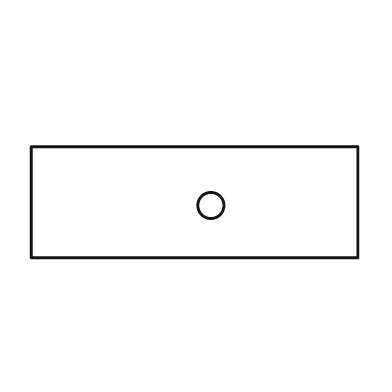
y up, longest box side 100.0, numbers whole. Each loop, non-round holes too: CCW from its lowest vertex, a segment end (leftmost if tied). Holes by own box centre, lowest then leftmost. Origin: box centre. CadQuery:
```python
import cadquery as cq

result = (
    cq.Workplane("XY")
    .moveTo(-50.0, -17.0)
    .lineTo(50.0, -17.0)
    .lineTo(50.0, 17.0)
    .lineTo(-50.0, 17.0)
    .close()
    .moveTo(5.0, -1.0)
    .circle(4.0)
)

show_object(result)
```